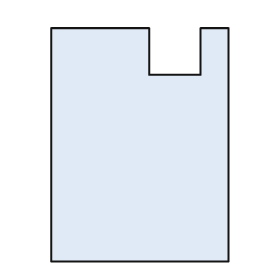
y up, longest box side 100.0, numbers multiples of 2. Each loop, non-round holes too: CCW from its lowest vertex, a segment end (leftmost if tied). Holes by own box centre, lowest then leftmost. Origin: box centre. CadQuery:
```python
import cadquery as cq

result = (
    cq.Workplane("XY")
    .moveTo(-38.0, -50.0)
    .lineTo(38.0, -50.0)
    .lineTo(38.0, 50.0)
    .lineTo(26.0, 50.0)
    .lineTo(26.0, 30.0)
    .lineTo(4.0, 30.0)
    .lineTo(4.0, 50.0)
    .lineTo(-38.0, 50.0)
    .close()
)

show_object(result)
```